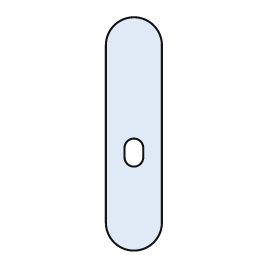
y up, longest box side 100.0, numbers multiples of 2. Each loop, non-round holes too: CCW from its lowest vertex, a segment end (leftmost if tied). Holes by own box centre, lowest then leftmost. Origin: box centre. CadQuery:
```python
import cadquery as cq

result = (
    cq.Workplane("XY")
    .moveTo(-12.0, -38.0)
    .threePointArc((0.0, -50.0), (12.0, -38.0))
    .lineTo(12.0, 38.0)
    .threePointArc((0.0, 50.0), (-12.0, 38.0))
    .close()
    .moveTo(-4.0, -10.0)
    .threePointArc((0.0, -14.0), (4.0, -10.0))
    .lineTo(4.0, -6.0)
    .threePointArc((0.0, -2.0), (-4.0, -6.0))
    .close()
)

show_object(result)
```